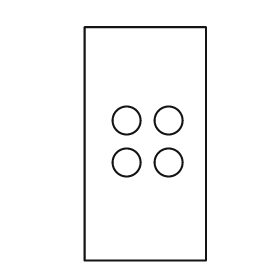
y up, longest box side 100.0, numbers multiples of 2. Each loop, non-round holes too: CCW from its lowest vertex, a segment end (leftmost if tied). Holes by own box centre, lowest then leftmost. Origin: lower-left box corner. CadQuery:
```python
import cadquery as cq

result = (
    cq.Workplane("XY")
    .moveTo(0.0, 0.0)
    .lineTo(52.0, 0.0)
    .lineTo(52.0, 100.0)
    .lineTo(0.0, 100.0)
    .close()
    .moveTo(18.0, 42.0)
    .circle(6.0)
    .moveTo(36.0, 42.0)
    .circle(6.0)
    .moveTo(18.0, 60.0)
    .circle(6.0)
    .moveTo(36.0, 60.0)
    .circle(6.0)
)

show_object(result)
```